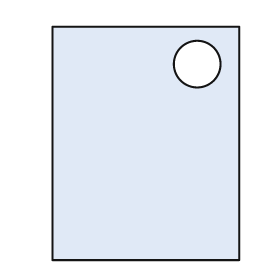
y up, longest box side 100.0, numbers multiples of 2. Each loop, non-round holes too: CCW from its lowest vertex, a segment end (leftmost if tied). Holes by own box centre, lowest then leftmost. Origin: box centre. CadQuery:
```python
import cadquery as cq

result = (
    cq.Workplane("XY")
    .moveTo(-40.0, -50.0)
    .lineTo(40.0, -50.0)
    .lineTo(40.0, 50.0)
    .lineTo(-40.0, 50.0)
    .close()
    .moveTo(22.0, 34.0)
    .circle(10.0)
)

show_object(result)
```